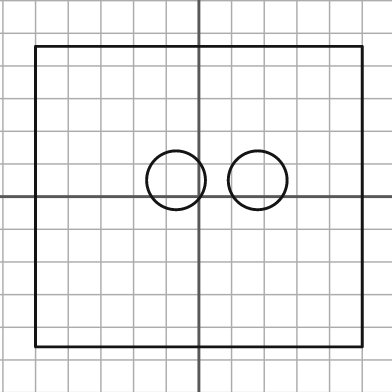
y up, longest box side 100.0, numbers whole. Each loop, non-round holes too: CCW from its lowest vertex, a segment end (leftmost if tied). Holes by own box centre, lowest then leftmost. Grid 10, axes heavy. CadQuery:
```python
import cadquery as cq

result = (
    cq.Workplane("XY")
    .moveTo(-50.0, -46.0)
    .lineTo(50.0, -46.0)
    .lineTo(50.0, 46.0)
    .lineTo(-50.0, 46.0)
    .close()
    .moveTo(-7.0, 5.0)
    .circle(9.0)
    .moveTo(18.0, 5.0)
    .circle(9.0)
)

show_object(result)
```